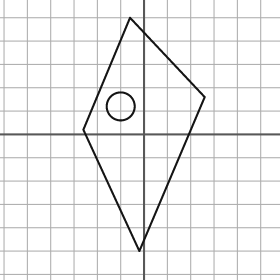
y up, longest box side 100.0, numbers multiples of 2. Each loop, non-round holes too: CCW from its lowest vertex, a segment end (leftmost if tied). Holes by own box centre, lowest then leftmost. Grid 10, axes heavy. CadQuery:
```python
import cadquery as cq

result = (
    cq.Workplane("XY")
    .moveTo(-2.0, -50.0)
    .lineTo(26.0, 16.0)
    .lineTo(-6.0, 50.0)
    .lineTo(-26.0, 2.0)
    .close()
    .moveTo(-10.0, 12.0)
    .circle(6.0)
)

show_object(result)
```